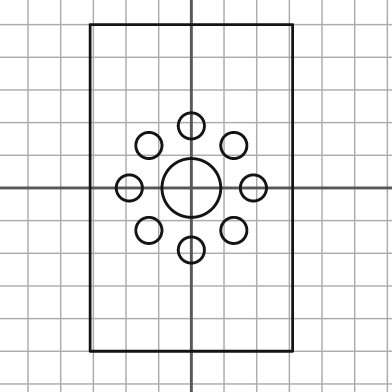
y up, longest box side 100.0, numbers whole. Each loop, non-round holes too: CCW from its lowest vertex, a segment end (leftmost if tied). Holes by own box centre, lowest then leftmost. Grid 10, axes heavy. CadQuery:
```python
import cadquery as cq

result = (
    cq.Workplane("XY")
    .moveTo(-31.0, -50.0)
    .lineTo(31.0, -50.0)
    .lineTo(31.0, 50.0)
    .lineTo(-31.0, 50.0)
    .close()
    .moveTo(0.0, -19.0)
    .circle(4.0)
    .moveTo(-13.0, -13.0)
    .circle(4.0)
    .moveTo(13.0, -13.0)
    .circle(4.0)
    .moveTo(-19.0, 0.0)
    .circle(4.0)
    .moveTo(0.0, 0.0)
    .circle(9.0)
    .moveTo(19.0, 0.0)
    .circle(4.0)
    .moveTo(-13.0, 13.0)
    .circle(4.0)
    .moveTo(13.0, 13.0)
    .circle(4.0)
    .moveTo(0.0, 19.0)
    .circle(4.0)
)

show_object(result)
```